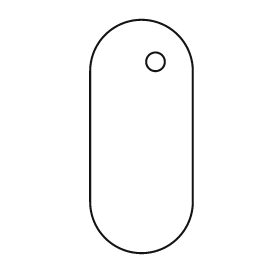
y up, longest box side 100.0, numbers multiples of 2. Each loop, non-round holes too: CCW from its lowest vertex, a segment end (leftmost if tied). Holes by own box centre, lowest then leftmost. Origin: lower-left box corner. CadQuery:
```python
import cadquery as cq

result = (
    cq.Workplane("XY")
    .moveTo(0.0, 22.0)
    .threePointArc((22.0, 0.0), (44.0, 22.0))
    .lineTo(44.0, 78.0)
    .threePointArc((22.0, 100.0), (0.0, 78.0))
    .close()
    .moveTo(28.0, 82.0)
    .circle(4.0)
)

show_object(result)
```